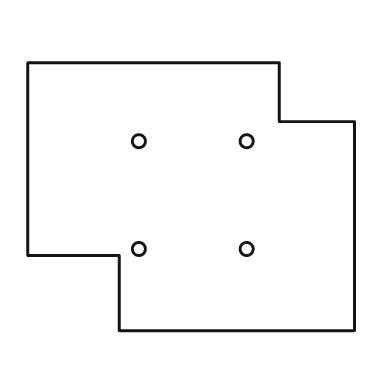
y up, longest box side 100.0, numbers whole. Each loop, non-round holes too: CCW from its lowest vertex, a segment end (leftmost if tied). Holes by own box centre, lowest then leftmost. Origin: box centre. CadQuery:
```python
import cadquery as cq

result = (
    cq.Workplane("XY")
    .moveTo(-22.0, -41.0)
    .lineTo(50.0, -41.0)
    .lineTo(50.0, 23.0)
    .lineTo(27.0, 23.0)
    .lineTo(27.0, 41.0)
    .lineTo(-50.0, 41.0)
    .lineTo(-50.0, -18.0)
    .lineTo(-22.0, -18.0)
    .close()
    .moveTo(-16.0, -16.0)
    .circle(2.0)
    .moveTo(17.0, -16.0)
    .circle(2.0)
    .moveTo(-16.0, 17.0)
    .circle(2.0)
    .moveTo(17.0, 17.0)
    .circle(2.0)
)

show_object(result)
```